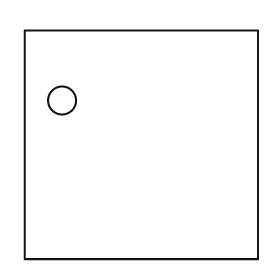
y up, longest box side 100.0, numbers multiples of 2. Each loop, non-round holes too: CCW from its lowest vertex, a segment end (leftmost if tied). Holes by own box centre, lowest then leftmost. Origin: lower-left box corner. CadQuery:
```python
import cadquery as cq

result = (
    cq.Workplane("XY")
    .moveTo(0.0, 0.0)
    .lineTo(100.0, 0.0)
    .lineTo(100.0, 98.0)
    .lineTo(0.0, 98.0)
    .close()
    .moveTo(16.0, 68.0)
    .circle(6.0)
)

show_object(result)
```